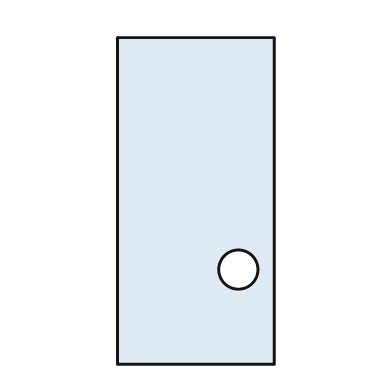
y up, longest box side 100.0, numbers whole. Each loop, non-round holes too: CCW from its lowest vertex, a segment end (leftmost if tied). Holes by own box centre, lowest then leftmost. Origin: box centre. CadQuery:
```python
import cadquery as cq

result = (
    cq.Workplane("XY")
    .moveTo(-24.0, -50.0)
    .lineTo(24.0, -50.0)
    .lineTo(24.0, 50.0)
    .lineTo(-24.0, 50.0)
    .close()
    .moveTo(13.0, -21.0)
    .circle(6.0)
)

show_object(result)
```